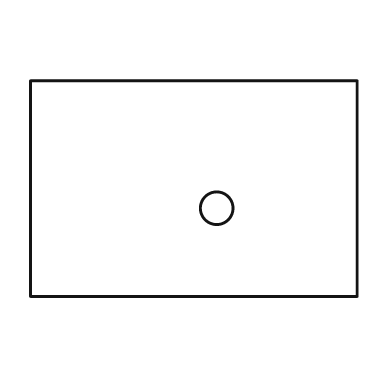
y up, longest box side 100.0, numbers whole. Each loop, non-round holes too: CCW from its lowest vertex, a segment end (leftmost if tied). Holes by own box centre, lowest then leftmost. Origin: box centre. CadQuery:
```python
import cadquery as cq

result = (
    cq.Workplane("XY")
    .moveTo(-50.0, -33.0)
    .lineTo(50.0, -33.0)
    .lineTo(50.0, 33.0)
    .lineTo(-50.0, 33.0)
    .close()
    .moveTo(7.0, -6.0)
    .circle(5.0)
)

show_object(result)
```